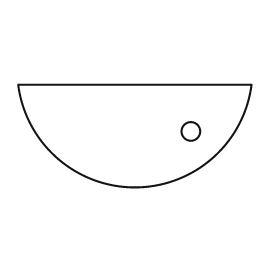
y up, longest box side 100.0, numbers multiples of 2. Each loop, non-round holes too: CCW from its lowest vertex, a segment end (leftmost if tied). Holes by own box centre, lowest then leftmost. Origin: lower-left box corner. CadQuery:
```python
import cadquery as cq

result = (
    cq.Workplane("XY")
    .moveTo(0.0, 44.0)
    .threePointArc((50.0, 0.0), (100.0, 44.0))
    .close()
    .moveTo(74.0, 24.0)
    .circle(4.0)
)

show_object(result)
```